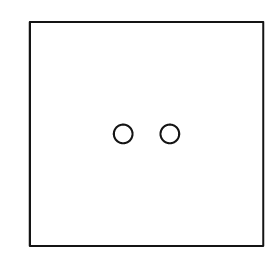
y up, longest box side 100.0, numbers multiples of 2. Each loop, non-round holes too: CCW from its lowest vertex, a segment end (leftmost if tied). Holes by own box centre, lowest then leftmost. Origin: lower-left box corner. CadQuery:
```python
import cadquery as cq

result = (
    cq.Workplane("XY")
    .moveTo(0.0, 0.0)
    .lineTo(100.0, 0.0)
    .lineTo(100.0, 96.0)
    .lineTo(0.0, 96.0)
    .close()
    .moveTo(40.0, 48.0)
    .circle(4.0)
    .moveTo(60.0, 48.0)
    .circle(4.0)
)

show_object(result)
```